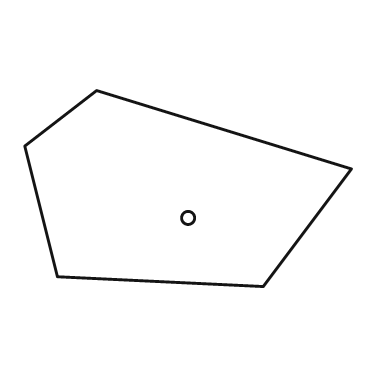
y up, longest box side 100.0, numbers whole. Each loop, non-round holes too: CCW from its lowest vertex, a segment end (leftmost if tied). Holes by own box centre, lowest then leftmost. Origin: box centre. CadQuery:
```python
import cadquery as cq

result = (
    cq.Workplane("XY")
    .moveTo(23.0, -30.0)
    .lineTo(50.0, 6.0)
    .lineTo(-28.0, 30.0)
    .lineTo(-50.0, 13.0)
    .lineTo(-40.0, -27.0)
    .close()
    .moveTo(0.0, -9.0)
    .circle(2.0)
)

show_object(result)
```